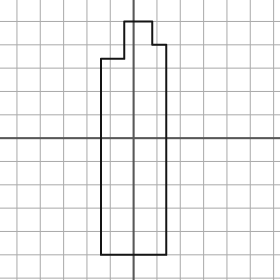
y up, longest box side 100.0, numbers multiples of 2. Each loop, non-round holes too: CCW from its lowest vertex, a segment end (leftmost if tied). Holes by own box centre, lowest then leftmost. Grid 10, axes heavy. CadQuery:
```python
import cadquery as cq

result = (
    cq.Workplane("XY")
    .moveTo(-14.0, -50.0)
    .lineTo(14.0, -50.0)
    .lineTo(14.0, 40.0)
    .lineTo(8.0, 40.0)
    .lineTo(8.0, 50.0)
    .lineTo(-4.0, 50.0)
    .lineTo(-4.0, 34.0)
    .lineTo(-14.0, 34.0)
    .close()
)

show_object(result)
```